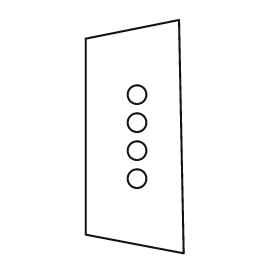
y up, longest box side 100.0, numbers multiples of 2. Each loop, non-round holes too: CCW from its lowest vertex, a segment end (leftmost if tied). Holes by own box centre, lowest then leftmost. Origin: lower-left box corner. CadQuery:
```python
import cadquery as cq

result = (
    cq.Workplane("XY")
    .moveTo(42.0, 0.0)
    .lineTo(40.0, 100.0)
    .lineTo(0.0, 92.0)
    .lineTo(0.0, 8.0)
    .close()
    .moveTo(22.0, 32.0)
    .circle(4.0)
    .moveTo(22.0, 44.0)
    .circle(4.0)
    .moveTo(22.0, 56.0)
    .circle(4.0)
    .moveTo(22.0, 68.0)
    .circle(4.0)
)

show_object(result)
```